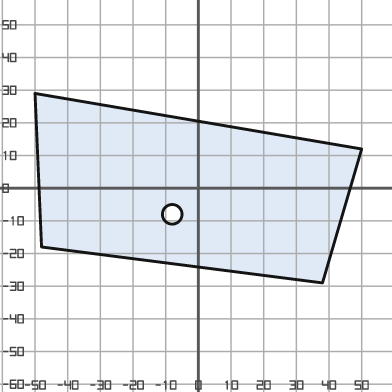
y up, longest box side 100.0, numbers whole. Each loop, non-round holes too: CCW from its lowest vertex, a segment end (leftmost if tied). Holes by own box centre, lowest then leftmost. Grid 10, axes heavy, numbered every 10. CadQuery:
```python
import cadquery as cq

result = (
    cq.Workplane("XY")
    .moveTo(38.0, -29.0)
    .lineTo(50.0, 12.0)
    .lineTo(-50.0, 29.0)
    .lineTo(-48.0, -18.0)
    .close()
    .moveTo(-8.0, -8.0)
    .circle(3.0)
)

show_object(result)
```